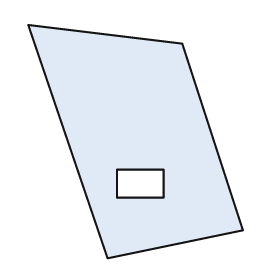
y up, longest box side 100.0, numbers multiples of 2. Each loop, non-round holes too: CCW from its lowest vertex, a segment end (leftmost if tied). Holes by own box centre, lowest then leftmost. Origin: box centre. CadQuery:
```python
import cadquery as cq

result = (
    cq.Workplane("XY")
    .moveTo(-12.0, -50.0)
    .lineTo(46.0, -38.0)
    .lineTo(20.0, 42.0)
    .lineTo(-46.0, 50.0)
    .close()
    .moveTo(-8.0, -24.0)
    .lineTo(12.0, -24.0)
    .lineTo(12.0, -12.0)
    .lineTo(-8.0, -12.0)
    .close()
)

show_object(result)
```